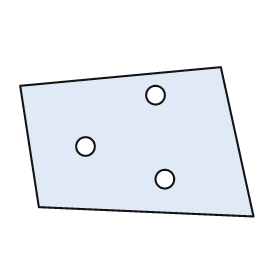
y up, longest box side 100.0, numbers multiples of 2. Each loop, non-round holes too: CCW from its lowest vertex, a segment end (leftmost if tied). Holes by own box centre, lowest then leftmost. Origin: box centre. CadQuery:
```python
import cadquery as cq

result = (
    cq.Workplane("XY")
    .moveTo(50.0, -32.0)
    .lineTo(36.0, 32.0)
    .lineTo(-50.0, 24.0)
    .lineTo(-42.0, -28.0)
    .close()
    .moveTo(12.0, -16.0)
    .circle(4.0)
    .moveTo(-22.0, -2.0)
    .circle(4.0)
    .moveTo(8.0, 20.0)
    .circle(4.0)
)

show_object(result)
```